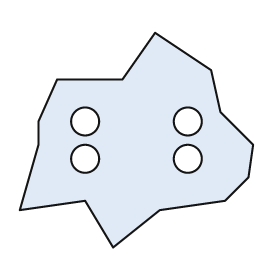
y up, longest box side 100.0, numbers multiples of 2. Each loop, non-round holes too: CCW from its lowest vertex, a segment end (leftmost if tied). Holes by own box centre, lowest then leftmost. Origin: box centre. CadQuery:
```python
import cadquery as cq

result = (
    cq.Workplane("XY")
    .moveTo(-10.0, -46.0)
    .lineTo(10.0, -30.0)
    .lineTo(38.0, -26.0)
    .lineTo(48.0, -16.0)
    .lineTo(50.0, -2.0)
    .lineTo(36.0, 12.0)
    .lineTo(32.0, 30.0)
    .lineTo(8.0, 46.0)
    .lineTo(-6.0, 26.0)
    .lineTo(-34.0, 26.0)
    .lineTo(-42.0, 8.0)
    .lineTo(-42.0, -2.0)
    .lineTo(-50.0, -30.0)
    .lineTo(-22.0, -26.0)
    .close()
    .moveTo(-22.0, -8.0)
    .circle(6.0)
    .moveTo(22.0, -8.0)
    .circle(6.0)
    .moveTo(-22.0, 8.0)
    .circle(6.0)
    .moveTo(22.0, 8.0)
    .circle(6.0)
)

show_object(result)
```